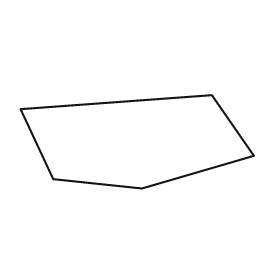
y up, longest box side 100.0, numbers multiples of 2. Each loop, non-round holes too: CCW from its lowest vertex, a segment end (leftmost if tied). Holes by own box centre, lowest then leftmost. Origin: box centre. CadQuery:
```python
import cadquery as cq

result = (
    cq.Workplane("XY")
    .moveTo(2.0, -20.0)
    .lineTo(50.0, -6.0)
    .lineTo(32.0, 20.0)
    .lineTo(-50.0, 14.0)
    .lineTo(-36.0, -16.0)
    .close()
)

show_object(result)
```